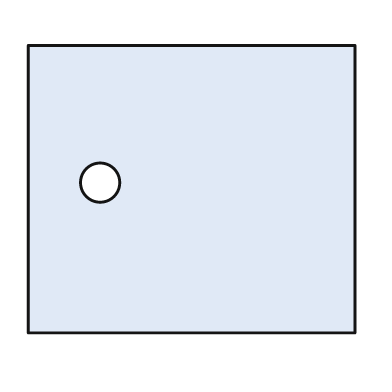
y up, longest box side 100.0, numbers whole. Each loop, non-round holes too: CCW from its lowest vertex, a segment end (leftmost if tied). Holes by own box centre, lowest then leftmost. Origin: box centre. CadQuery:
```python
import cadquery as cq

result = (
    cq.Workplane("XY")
    .moveTo(-50.0, -44.0)
    .lineTo(50.0, -44.0)
    .lineTo(50.0, 44.0)
    .lineTo(-50.0, 44.0)
    .close()
    .moveTo(-28.0, 2.0)
    .circle(6.0)
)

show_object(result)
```